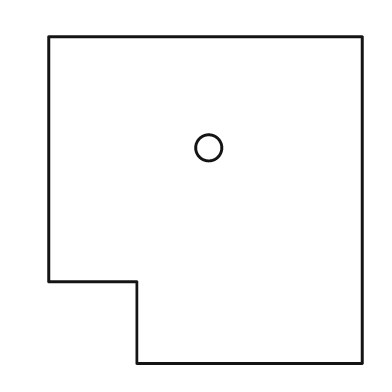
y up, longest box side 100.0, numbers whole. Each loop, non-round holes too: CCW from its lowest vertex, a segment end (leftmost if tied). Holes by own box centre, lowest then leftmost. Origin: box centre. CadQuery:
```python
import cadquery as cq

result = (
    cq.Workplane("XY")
    .moveTo(-21.0, -50.0)
    .lineTo(48.0, -50.0)
    .lineTo(48.0, 50.0)
    .lineTo(-48.0, 50.0)
    .lineTo(-48.0, -25.0)
    .lineTo(-21.0, -25.0)
    .close()
    .moveTo(1.0, 16.0)
    .circle(4.0)
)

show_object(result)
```